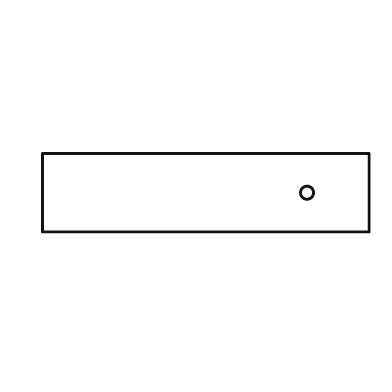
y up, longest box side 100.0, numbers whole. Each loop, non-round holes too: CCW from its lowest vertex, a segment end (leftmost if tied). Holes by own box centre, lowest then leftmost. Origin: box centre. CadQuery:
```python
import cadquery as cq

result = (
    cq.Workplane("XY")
    .moveTo(-50.0, -12.0)
    .lineTo(50.0, -12.0)
    .lineTo(50.0, 12.0)
    .lineTo(-50.0, 12.0)
    .close()
    .moveTo(31.0, 0.0)
    .circle(2.0)
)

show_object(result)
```